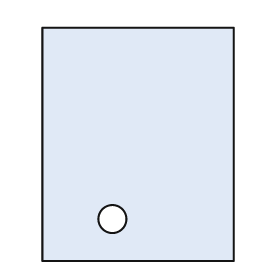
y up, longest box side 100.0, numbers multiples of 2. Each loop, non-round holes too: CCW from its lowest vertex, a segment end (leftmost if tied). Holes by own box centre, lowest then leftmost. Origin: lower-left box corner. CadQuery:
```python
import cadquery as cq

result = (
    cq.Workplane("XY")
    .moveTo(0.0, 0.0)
    .lineTo(82.0, 0.0)
    .lineTo(82.0, 100.0)
    .lineTo(0.0, 100.0)
    .close()
    .moveTo(30.0, 18.0)
    .circle(6.0)
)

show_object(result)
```